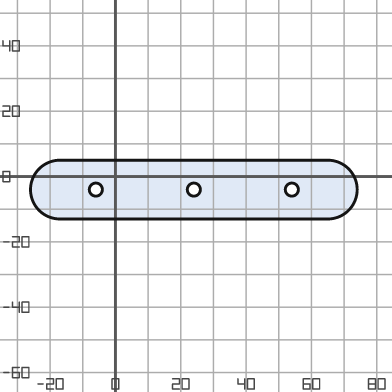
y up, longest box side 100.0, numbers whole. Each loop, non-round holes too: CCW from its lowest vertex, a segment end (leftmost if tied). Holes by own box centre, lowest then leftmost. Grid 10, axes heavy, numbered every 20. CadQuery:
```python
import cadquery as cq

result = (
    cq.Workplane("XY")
    .moveTo(-17.0, -13.0)
    .lineTo(65.0, -13.0)
    .threePointArc((74.0, -4.0), (65.0, 5.0))
    .lineTo(-17.0, 5.0)
    .threePointArc((-26.0, -4.0), (-17.0, -13.0))
    .close()
    .moveTo(-6.0, -4.0)
    .circle(2.0)
    .moveTo(24.0, -4.0)
    .circle(2.0)
    .moveTo(54.0, -4.0)
    .circle(2.0)
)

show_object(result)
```